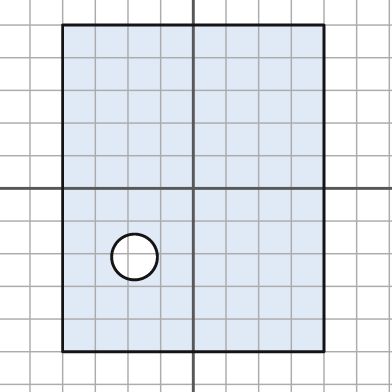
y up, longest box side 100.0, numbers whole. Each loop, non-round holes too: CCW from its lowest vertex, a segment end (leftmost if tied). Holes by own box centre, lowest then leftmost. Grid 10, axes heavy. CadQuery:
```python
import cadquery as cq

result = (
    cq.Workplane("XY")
    .moveTo(-40.0, -50.0)
    .lineTo(40.0, -50.0)
    .lineTo(40.0, 50.0)
    .lineTo(-40.0, 50.0)
    .close()
    .moveTo(-18.0, -21.0)
    .circle(7.0)
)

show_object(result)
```